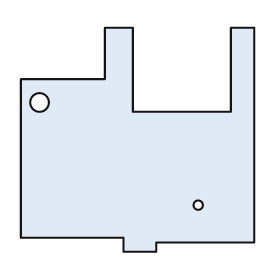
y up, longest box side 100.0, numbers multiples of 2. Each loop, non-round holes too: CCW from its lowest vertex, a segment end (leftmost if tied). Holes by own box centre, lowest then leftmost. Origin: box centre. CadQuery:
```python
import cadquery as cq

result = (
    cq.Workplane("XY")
    .moveTo(-6.0, -48.0)
    .lineTo(8.0, -48.0)
    .lineTo(8.0, -44.0)
    .lineTo(50.0, -44.0)
    .lineTo(50.0, 48.0)
    .lineTo(40.0, 48.0)
    .lineTo(40.0, 12.0)
    .lineTo(-2.0, 12.0)
    .lineTo(-2.0, 48.0)
    .lineTo(-14.0, 48.0)
    .lineTo(-14.0, 26.0)
    .lineTo(-50.0, 26.0)
    .lineTo(-50.0, -42.0)
    .lineTo(-6.0, -42.0)
    .close()
    .moveTo(26.0, -28.0)
    .circle(2.0)
    .moveTo(-42.0, 16.0)
    .circle(4.0)
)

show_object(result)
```